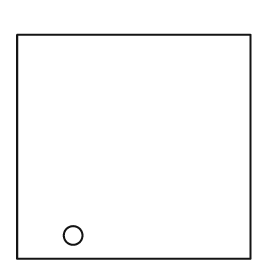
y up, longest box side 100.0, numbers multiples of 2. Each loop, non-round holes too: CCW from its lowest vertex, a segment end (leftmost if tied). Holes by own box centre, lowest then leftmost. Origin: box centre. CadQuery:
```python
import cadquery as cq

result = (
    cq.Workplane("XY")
    .moveTo(-50.0, -48.0)
    .lineTo(50.0, -48.0)
    .lineTo(50.0, 48.0)
    .lineTo(-50.0, 48.0)
    .close()
    .moveTo(-26.0, -38.0)
    .circle(4.0)
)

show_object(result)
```